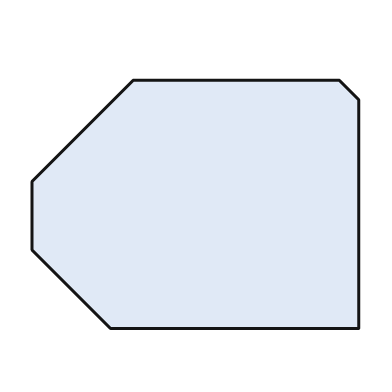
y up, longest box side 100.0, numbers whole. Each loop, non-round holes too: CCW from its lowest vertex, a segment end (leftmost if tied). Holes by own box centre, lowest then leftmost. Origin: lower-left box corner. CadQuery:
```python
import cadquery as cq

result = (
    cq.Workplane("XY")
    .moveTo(24.0, 0.0)
    .lineTo(100.0, 0.0)
    .lineTo(100.0, 70.0)
    .lineTo(94.0, 76.0)
    .lineTo(31.0, 76.0)
    .lineTo(0.0, 45.0)
    .lineTo(0.0, 24.0)
    .close()
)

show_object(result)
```